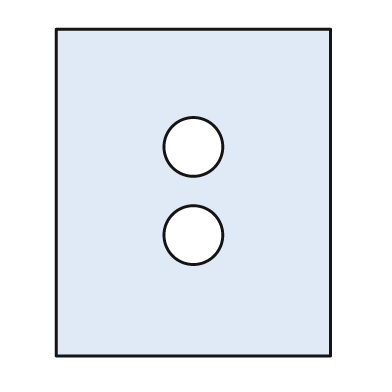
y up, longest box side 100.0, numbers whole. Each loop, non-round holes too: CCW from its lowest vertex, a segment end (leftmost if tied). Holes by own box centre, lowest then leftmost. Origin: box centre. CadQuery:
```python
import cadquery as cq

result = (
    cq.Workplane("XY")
    .moveTo(-42.0, -50.0)
    .lineTo(42.0, -50.0)
    .lineTo(42.0, 50.0)
    .lineTo(-42.0, 50.0)
    .close()
    .moveTo(0.0, -13.0)
    .circle(9.0)
    .moveTo(0.0, 14.0)
    .circle(9.0)
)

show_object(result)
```